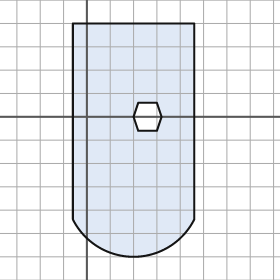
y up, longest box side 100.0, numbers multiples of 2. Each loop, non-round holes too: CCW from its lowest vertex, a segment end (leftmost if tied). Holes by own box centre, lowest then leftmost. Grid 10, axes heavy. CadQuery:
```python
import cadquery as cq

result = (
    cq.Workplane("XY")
    .moveTo(-6.0, -44.0)
    .threePointArc((20.0, -60.0), (46.0, -44.0))
    .lineTo(46.0, 40.0)
    .lineTo(-6.0, 40.0)
    .close()
    .moveTo(22.0, -6.0)
    .lineTo(30.0, -6.0)
    .lineTo(32.0, 0.0)
    .lineTo(30.0, 6.0)
    .lineTo(22.0, 6.0)
    .lineTo(20.0, 0.0)
    .close()
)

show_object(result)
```